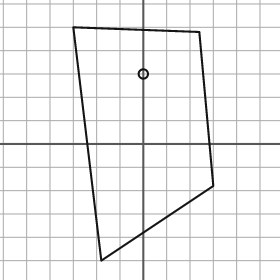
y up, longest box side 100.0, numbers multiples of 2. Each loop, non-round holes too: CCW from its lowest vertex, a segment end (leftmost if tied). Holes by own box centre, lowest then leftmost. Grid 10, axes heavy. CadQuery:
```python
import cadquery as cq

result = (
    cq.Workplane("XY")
    .moveTo(-18.0, -50.0)
    .lineTo(30.0, -18.0)
    .lineTo(24.0, 48.0)
    .lineTo(-30.0, 50.0)
    .close()
    .moveTo(0.0, 30.0)
    .circle(2.0)
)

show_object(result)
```